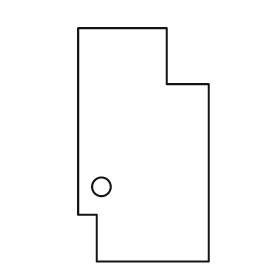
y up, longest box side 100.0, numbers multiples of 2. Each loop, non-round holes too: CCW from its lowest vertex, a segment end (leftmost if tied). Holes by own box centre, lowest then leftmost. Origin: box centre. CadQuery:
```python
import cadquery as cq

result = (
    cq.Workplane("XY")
    .moveTo(-20.0, -50.0)
    .lineTo(28.0, -50.0)
    .lineTo(28.0, 26.0)
    .lineTo(10.0, 26.0)
    .lineTo(10.0, 50.0)
    .lineTo(-28.0, 50.0)
    .lineTo(-28.0, -30.0)
    .lineTo(-20.0, -30.0)
    .close()
    .moveTo(-18.0, -18.0)
    .circle(4.0)
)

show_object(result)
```